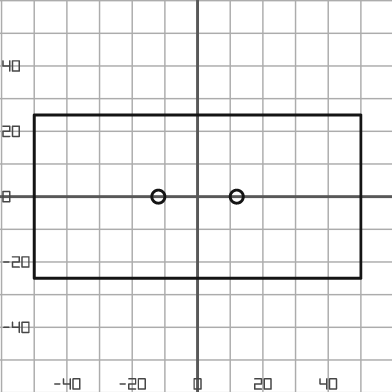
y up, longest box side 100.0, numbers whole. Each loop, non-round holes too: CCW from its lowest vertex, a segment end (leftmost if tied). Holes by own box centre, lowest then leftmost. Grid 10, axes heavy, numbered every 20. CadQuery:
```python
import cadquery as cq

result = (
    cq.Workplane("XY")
    .moveTo(-50.0, -25.0)
    .lineTo(50.0, -25.0)
    .lineTo(50.0, 25.0)
    .lineTo(-50.0, 25.0)
    .close()
    .moveTo(-12.0, 0.0)
    .circle(2.0)
    .moveTo(12.0, 0.0)
    .circle(2.0)
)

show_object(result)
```